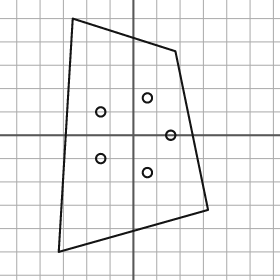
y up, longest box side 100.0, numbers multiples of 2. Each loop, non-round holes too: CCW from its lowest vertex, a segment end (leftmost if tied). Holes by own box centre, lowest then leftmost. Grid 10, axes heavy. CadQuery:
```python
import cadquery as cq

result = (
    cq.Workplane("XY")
    .moveTo(-32.0, -50.0)
    .lineTo(32.0, -32.0)
    .lineTo(18.0, 36.0)
    .lineTo(-26.0, 50.0)
    .close()
    .moveTo(6.0, -16.0)
    .circle(2.0)
    .moveTo(-14.0, -10.0)
    .circle(2.0)
    .moveTo(16.0, 0.0)
    .circle(2.0)
    .moveTo(-14.0, 10.0)
    .circle(2.0)
    .moveTo(6.0, 16.0)
    .circle(2.0)
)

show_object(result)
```